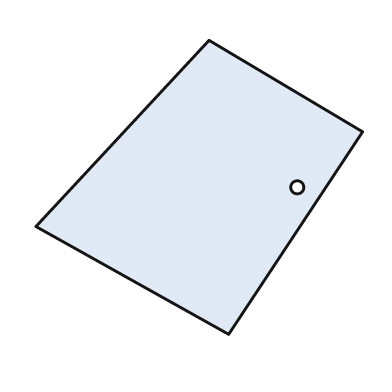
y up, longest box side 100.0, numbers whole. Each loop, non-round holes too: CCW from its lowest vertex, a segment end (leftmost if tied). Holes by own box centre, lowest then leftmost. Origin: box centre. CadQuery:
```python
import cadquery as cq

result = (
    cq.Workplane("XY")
    .moveTo(9.0, -45.0)
    .lineTo(50.0, 17.0)
    .lineTo(3.0, 45.0)
    .lineTo(-50.0, -12.0)
    .close()
    .moveTo(30.0, 0.0)
    .circle(2.0)
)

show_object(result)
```